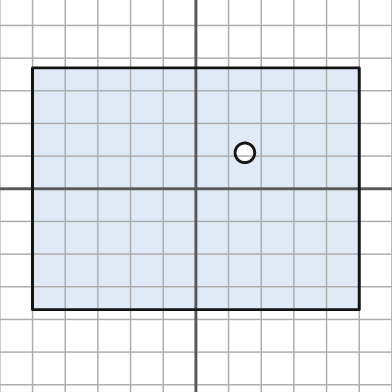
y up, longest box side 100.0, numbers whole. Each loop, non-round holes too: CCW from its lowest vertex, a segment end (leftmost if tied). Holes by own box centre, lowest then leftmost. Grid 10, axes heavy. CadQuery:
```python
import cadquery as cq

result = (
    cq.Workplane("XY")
    .moveTo(-50.0, -37.0)
    .lineTo(50.0, -37.0)
    .lineTo(50.0, 37.0)
    .lineTo(-50.0, 37.0)
    .close()
    .moveTo(15.0, 11.0)
    .circle(3.0)
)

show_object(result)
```